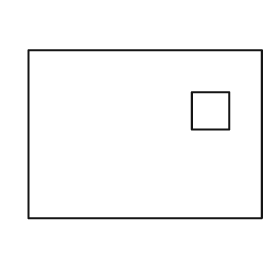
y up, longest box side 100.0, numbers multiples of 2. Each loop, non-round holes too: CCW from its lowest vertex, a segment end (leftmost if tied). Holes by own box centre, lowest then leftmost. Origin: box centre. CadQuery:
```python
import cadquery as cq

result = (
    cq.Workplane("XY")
    .moveTo(-50.0, -36.0)
    .lineTo(50.0, -36.0)
    .lineTo(50.0, 36.0)
    .lineTo(-50.0, 36.0)
    .close()
    .moveTo(20.0, 2.0)
    .lineTo(36.0, 2.0)
    .lineTo(36.0, 18.0)
    .lineTo(20.0, 18.0)
    .close()
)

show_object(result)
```